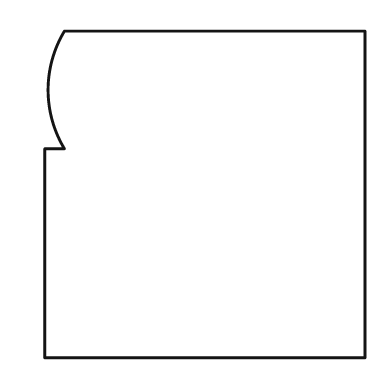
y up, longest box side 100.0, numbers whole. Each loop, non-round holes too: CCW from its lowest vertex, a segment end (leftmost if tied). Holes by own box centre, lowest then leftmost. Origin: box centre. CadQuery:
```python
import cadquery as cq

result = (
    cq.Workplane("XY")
    .moveTo(-49.0, -50.0)
    .lineTo(49.0, -50.0)
    .lineTo(49.0, 50.0)
    .lineTo(-43.0, 50.0)
    .threePointArc((-48.0, 32.0), (-43.0, 14.0))
    .lineTo(-49.0, 14.0)
    .close()
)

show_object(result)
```